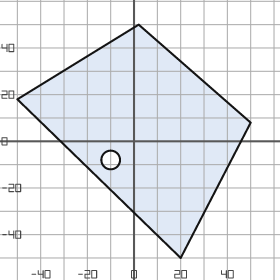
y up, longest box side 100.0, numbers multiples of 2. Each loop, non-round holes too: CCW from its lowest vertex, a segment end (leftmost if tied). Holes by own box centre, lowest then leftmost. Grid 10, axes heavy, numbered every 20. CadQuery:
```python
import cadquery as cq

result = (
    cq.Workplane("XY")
    .moveTo(20.0, -50.0)
    .lineTo(50.0, 8.0)
    .lineTo(2.0, 50.0)
    .lineTo(-50.0, 18.0)
    .close()
    .moveTo(-10.0, -8.0)
    .circle(4.0)
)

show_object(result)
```